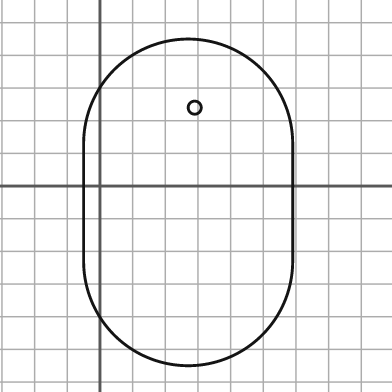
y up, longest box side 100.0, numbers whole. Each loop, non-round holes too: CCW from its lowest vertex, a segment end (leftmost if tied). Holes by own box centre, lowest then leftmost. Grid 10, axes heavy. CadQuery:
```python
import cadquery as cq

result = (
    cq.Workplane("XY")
    .moveTo(-5.0, -23.0)
    .threePointArc((27.0, -55.0), (59.0, -23.0))
    .lineTo(59.0, 13.0)
    .threePointArc((27.0, 45.0), (-5.0, 13.0))
    .close()
    .moveTo(29.0, 24.0)
    .circle(2.0)
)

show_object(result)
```